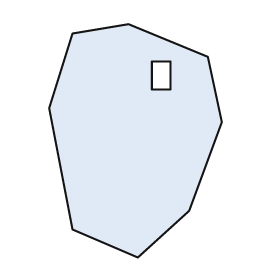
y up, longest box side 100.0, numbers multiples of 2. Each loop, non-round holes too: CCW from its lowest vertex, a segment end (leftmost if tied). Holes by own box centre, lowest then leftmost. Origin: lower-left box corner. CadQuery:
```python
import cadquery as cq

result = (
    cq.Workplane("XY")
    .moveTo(38.0, 0.0)
    .lineTo(60.0, 20.0)
    .lineTo(74.0, 58.0)
    .lineTo(68.0, 86.0)
    .lineTo(34.0, 100.0)
    .lineTo(10.0, 96.0)
    .lineTo(0.0, 64.0)
    .lineTo(10.0, 12.0)
    .close()
    .moveTo(44.0, 72.0)
    .lineTo(52.0, 72.0)
    .lineTo(52.0, 84.0)
    .lineTo(44.0, 84.0)
    .close()
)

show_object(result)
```